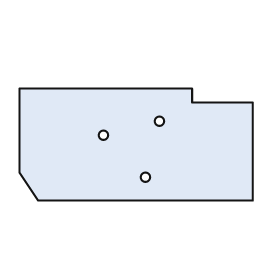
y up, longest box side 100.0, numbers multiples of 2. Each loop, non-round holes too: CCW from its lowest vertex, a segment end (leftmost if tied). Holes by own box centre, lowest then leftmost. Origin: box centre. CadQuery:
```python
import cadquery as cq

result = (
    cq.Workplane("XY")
    .moveTo(-42.0, -24.0)
    .lineTo(50.0, -24.0)
    .lineTo(50.0, 18.0)
    .lineTo(24.0, 18.0)
    .lineTo(24.0, 24.0)
    .lineTo(-50.0, 24.0)
    .lineTo(-50.0, -12.0)
    .close()
    .moveTo(4.0, -14.0)
    .circle(2.0)
    .moveTo(-14.0, 4.0)
    .circle(2.0)
    .moveTo(10.0, 10.0)
    .circle(2.0)
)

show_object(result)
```